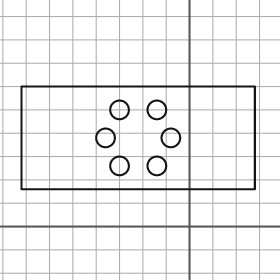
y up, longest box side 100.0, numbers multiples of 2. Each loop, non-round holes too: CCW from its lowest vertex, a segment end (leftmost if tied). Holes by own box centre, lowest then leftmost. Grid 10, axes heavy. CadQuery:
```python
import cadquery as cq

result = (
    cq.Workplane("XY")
    .moveTo(-72.0, 16.0)
    .lineTo(28.0, 16.0)
    .lineTo(28.0, 60.0)
    .lineTo(-72.0, 60.0)
    .close()
    .moveTo(-30.0, 26.0)
    .circle(4.0)
    .moveTo(-14.0, 26.0)
    .circle(4.0)
    .moveTo(-36.0, 38.0)
    .circle(4.0)
    .moveTo(-8.0, 38.0)
    .circle(4.0)
    .moveTo(-30.0, 50.0)
    .circle(4.0)
    .moveTo(-14.0, 50.0)
    .circle(4.0)
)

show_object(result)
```